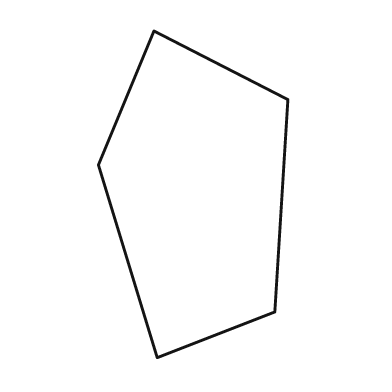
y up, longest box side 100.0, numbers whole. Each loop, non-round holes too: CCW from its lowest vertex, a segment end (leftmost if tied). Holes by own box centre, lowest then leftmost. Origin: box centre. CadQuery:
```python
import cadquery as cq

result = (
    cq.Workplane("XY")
    .moveTo(-11.0, -50.0)
    .lineTo(25.0, -36.0)
    .lineTo(29.0, 29.0)
    .lineTo(-12.0, 50.0)
    .lineTo(-29.0, 9.0)
    .close()
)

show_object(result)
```